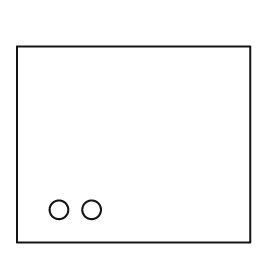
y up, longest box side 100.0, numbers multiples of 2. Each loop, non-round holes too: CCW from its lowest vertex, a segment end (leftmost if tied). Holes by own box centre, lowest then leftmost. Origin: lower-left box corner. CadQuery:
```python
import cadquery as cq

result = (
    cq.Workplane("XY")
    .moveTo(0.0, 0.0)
    .lineTo(100.0, 0.0)
    .lineTo(100.0, 84.0)
    .lineTo(0.0, 84.0)
    .close()
    .moveTo(18.0, 14.0)
    .circle(4.0)
    .moveTo(32.0, 14.0)
    .circle(4.0)
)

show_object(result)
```